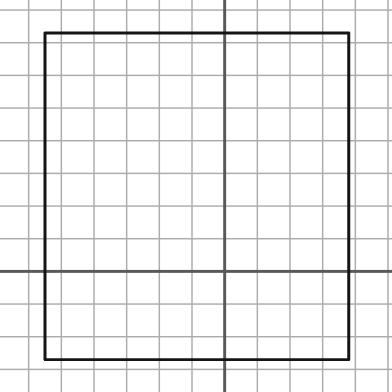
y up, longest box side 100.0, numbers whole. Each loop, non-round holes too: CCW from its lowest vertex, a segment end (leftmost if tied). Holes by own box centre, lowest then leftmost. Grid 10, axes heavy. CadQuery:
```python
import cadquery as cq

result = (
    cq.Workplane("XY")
    .moveTo(-55.0, -27.0)
    .lineTo(38.0, -27.0)
    .lineTo(38.0, 73.0)
    .lineTo(-55.0, 73.0)
    .close()
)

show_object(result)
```